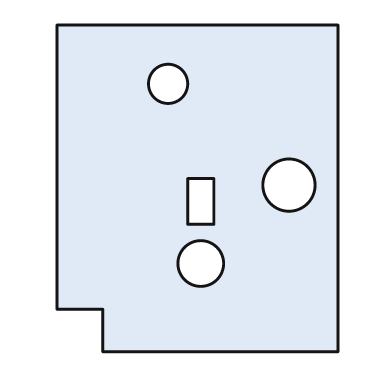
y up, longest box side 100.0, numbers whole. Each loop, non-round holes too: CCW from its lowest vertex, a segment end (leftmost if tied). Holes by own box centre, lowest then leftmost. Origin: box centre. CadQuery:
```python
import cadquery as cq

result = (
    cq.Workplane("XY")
    .moveTo(-29.0, -50.0)
    .lineTo(43.0, -50.0)
    .lineTo(43.0, 50.0)
    .lineTo(-43.0, 50.0)
    .lineTo(-43.0, -37.0)
    .lineTo(-29.0, -37.0)
    .close()
    .moveTo(1.0, -23.0)
    .circle(7.0)
    .moveTo(-3.0, -11.0)
    .lineTo(5.0, -11.0)
    .lineTo(5.0, 3.0)
    .lineTo(-3.0, 3.0)
    .close()
    .moveTo(28.0, 1.0)
    .circle(8.0)
    .moveTo(-9.0, 32.0)
    .circle(6.0)
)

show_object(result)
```